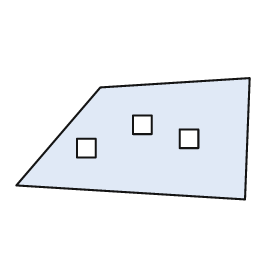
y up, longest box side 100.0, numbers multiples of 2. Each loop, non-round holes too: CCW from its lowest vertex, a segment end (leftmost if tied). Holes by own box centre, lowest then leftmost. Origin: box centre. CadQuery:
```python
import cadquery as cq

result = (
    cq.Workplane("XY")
    .moveTo(48.0, -26.0)
    .lineTo(50.0, 26.0)
    .lineTo(-14.0, 22.0)
    .lineTo(-50.0, -20.0)
    .close()
    .moveTo(-24.0, -8.0)
    .lineTo(-16.0, -8.0)
    .lineTo(-16.0, 0.0)
    .lineTo(-24.0, 0.0)
    .close()
    .moveTo(20.0, -4.0)
    .lineTo(28.0, -4.0)
    .lineTo(28.0, 4.0)
    .lineTo(20.0, 4.0)
    .close()
    .moveTo(0.0, 2.0)
    .lineTo(8.0, 2.0)
    .lineTo(8.0, 10.0)
    .lineTo(0.0, 10.0)
    .close()
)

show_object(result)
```